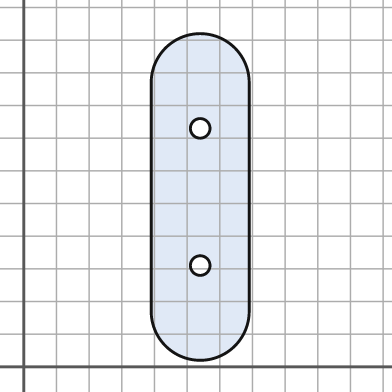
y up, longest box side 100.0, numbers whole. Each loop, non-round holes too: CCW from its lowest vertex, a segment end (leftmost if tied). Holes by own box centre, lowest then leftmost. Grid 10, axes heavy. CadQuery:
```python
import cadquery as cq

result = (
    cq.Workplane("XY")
    .moveTo(39.0, 17.0)
    .threePointArc((54.0, 2.0), (69.0, 17.0))
    .lineTo(69.0, 87.0)
    .threePointArc((54.0, 102.0), (39.0, 87.0))
    .close()
    .moveTo(54.0, 31.0)
    .circle(3.0)
    .moveTo(54.0, 73.0)
    .circle(3.0)
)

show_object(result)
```